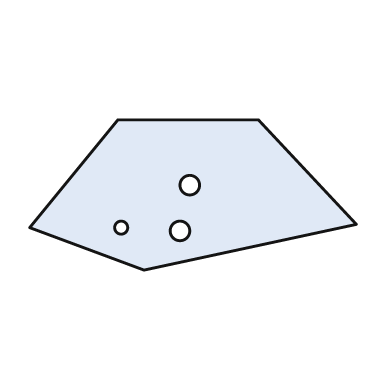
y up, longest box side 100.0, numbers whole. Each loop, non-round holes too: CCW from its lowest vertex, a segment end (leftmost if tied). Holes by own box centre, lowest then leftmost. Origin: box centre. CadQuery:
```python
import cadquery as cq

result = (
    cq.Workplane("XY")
    .moveTo(-15.0, -23.0)
    .lineTo(50.0, -9.0)
    .lineTo(20.0, 23.0)
    .lineTo(-23.0, 23.0)
    .lineTo(-50.0, -10.0)
    .close()
    .moveTo(-4.0, -11.0)
    .circle(3.0)
    .moveTo(-22.0, -10.0)
    .circle(2.0)
    .moveTo(-1.0, 3.0)
    .circle(3.0)
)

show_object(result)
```